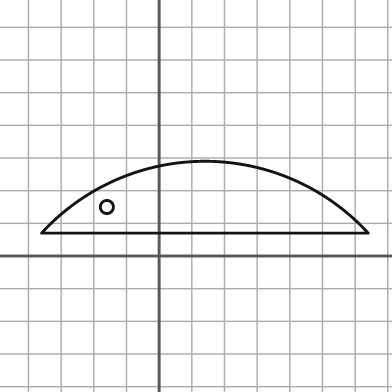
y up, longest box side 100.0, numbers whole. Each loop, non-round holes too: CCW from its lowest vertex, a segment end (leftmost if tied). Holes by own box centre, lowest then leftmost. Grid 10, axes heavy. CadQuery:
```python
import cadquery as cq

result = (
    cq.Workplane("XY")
    .moveTo(-36.0, 7.0)
    .lineTo(64.0, 7.0)
    .threePointArc((14.0, 29.0), (-36.0, 7.0))
    .close()
    .moveTo(-16.0, 15.0)
    .circle(2.0)
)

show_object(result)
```